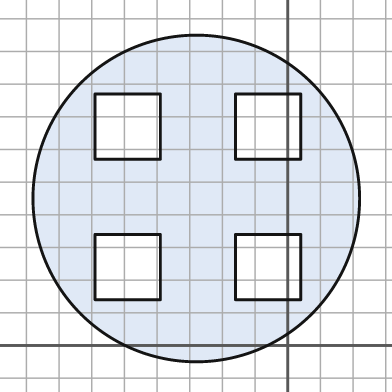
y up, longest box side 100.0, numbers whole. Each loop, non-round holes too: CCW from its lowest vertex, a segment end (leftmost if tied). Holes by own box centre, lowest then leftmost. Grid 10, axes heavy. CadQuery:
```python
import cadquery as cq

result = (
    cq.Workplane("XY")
    .moveTo(-28.0, 45.0)
    .circle(50.0)
    .moveTo(-59.0, 14.0)
    .lineTo(-39.0, 14.0)
    .lineTo(-39.0, 34.0)
    .lineTo(-59.0, 34.0)
    .close()
    .moveTo(-16.0, 14.0)
    .lineTo(4.0, 14.0)
    .lineTo(4.0, 34.0)
    .lineTo(-16.0, 34.0)
    .close()
    .moveTo(-59.0, 57.0)
    .lineTo(-39.0, 57.0)
    .lineTo(-39.0, 77.0)
    .lineTo(-59.0, 77.0)
    .close()
    .moveTo(-16.0, 57.0)
    .lineTo(4.0, 57.0)
    .lineTo(4.0, 77.0)
    .lineTo(-16.0, 77.0)
    .close()
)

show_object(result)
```